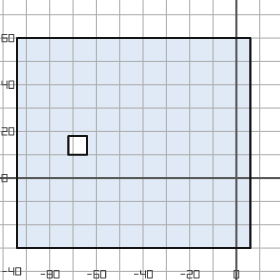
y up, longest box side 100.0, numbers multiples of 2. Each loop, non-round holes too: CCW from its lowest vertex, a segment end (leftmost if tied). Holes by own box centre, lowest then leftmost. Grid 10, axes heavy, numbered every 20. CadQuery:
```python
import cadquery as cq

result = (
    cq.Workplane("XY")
    .moveTo(-94.0, -30.0)
    .lineTo(6.0, -30.0)
    .lineTo(6.0, 60.0)
    .lineTo(-94.0, 60.0)
    .close()
    .moveTo(-72.0, 10.0)
    .lineTo(-64.0, 10.0)
    .lineTo(-64.0, 18.0)
    .lineTo(-72.0, 18.0)
    .close()
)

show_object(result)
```